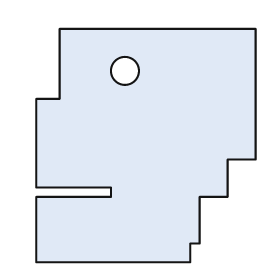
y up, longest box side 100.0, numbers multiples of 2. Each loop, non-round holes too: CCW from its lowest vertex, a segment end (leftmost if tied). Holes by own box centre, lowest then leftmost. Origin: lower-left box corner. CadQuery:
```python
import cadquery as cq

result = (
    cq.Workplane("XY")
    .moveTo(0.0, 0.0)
    .lineTo(66.0, 0.0)
    .lineTo(66.0, 8.0)
    .lineTo(70.0, 8.0)
    .lineTo(70.0, 28.0)
    .lineTo(82.0, 28.0)
    .lineTo(82.0, 44.0)
    .lineTo(94.0, 44.0)
    .lineTo(94.0, 100.0)
    .lineTo(10.0, 100.0)
    .lineTo(10.0, 70.0)
    .lineTo(0.0, 70.0)
    .lineTo(0.0, 32.0)
    .lineTo(32.0, 32.0)
    .lineTo(32.0, 28.0)
    .lineTo(0.0, 28.0)
    .close()
    .moveTo(38.0, 82.0)
    .circle(6.0)
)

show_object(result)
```